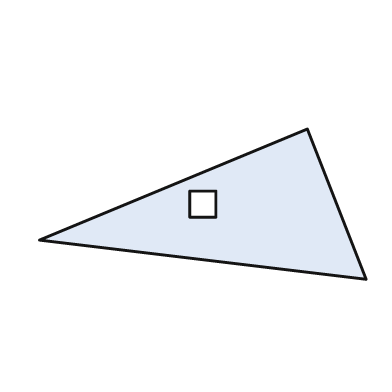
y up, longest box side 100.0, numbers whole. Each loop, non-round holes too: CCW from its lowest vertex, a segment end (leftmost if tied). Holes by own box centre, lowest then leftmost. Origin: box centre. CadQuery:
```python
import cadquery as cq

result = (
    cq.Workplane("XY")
    .moveTo(50.0, -23.0)
    .lineTo(32.0, 23.0)
    .lineTo(-50.0, -11.0)
    .close()
    .moveTo(-4.0, -4.0)
    .lineTo(4.0, -4.0)
    .lineTo(4.0, 4.0)
    .lineTo(-4.0, 4.0)
    .close()
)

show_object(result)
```